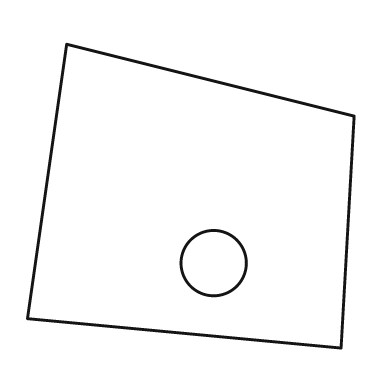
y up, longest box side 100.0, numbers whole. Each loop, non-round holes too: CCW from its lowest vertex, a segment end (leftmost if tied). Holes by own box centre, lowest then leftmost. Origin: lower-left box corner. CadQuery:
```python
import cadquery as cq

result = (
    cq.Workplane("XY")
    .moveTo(96.0, 0.0)
    .lineTo(100.0, 71.0)
    .lineTo(12.0, 93.0)
    .lineTo(0.0, 9.0)
    .close()
    .moveTo(57.0, 26.0)
    .circle(10.0)
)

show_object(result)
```